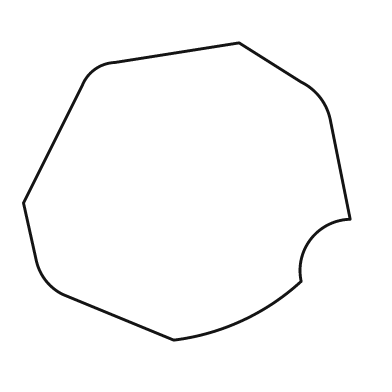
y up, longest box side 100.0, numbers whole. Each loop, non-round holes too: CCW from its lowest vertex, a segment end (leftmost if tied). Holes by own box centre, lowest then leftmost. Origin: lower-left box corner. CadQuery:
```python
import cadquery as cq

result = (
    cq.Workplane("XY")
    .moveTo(46.0, 0.0)
    .threePointArc((67.0, 6.0), (85.0, 18.0))
    .threePointArc((88.0, 31.0), (100.0, 37.0))
    .lineTo(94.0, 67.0)
    .threePointArc((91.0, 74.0), (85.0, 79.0))
    .lineTo(66.0, 91.0)
    .lineTo(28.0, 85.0)
    .threePointArc((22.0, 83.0), (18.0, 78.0))
    .lineTo(0.0, 42.0)
    .lineTo(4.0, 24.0)
    .threePointArc((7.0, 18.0), (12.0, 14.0))
    .close()
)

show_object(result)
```